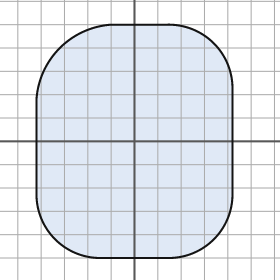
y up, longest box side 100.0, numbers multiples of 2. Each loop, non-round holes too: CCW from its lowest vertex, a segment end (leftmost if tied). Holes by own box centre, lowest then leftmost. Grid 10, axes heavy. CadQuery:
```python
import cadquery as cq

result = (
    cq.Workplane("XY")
    .moveTo(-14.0, -50.0)
    .lineTo(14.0, -50.0)
    .threePointArc((34.0, -42.0), (42.0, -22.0))
    .lineTo(42.0, 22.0)
    .threePointArc((34.0, 42.0), (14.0, 50.0))
    .lineTo(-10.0, 50.0)
    .threePointArc((-32.0, 40.0), (-42.0, 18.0))
    .lineTo(-42.0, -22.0)
    .threePointArc((-34.0, -42.0), (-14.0, -50.0))
    .close()
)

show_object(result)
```